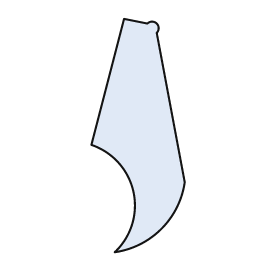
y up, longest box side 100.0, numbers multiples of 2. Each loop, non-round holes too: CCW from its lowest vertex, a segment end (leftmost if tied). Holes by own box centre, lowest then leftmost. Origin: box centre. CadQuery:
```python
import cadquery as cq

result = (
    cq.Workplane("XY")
    .moveTo(-10.0, -50.0)
    .threePointArc((10.0, -40.0), (20.0, -20.0))
    .lineTo(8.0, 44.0)
    .threePointArc((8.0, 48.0), (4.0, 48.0))
    .lineTo(-6.0, 50.0)
    .lineTo(-20.0, -4.0)
    .threePointArc((-2.0, -24.0), (-10.0, -50.0))
    .close()
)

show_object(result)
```